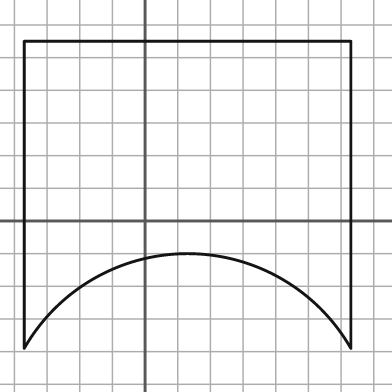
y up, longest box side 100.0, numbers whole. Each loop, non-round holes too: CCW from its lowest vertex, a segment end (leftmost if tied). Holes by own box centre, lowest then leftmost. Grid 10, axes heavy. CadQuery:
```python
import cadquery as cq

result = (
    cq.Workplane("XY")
    .moveTo(-37.0, -39.0)
    .threePointArc((13.0, -10.0), (63.0, -39.0))
    .lineTo(63.0, 55.0)
    .lineTo(-37.0, 55.0)
    .close()
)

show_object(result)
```